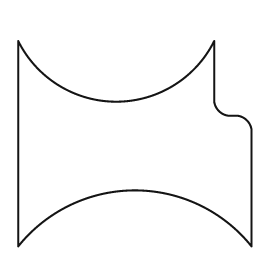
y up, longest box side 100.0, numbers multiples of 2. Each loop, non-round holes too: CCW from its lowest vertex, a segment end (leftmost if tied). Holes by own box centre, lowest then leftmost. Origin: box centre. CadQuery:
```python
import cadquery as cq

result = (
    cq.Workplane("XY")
    .moveTo(-50.0, -44.0)
    .threePointArc((0.0, -20.0), (50.0, -44.0))
    .lineTo(50.0, 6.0)
    .threePointArc((48.0, 10.0), (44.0, 12.0))
    .lineTo(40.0, 12.0)
    .threePointArc((36.0, 14.0), (34.0, 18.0))
    .lineTo(34.0, 44.0)
    .threePointArc((-8.0, 18.0), (-50.0, 44.0))
    .close()
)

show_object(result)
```